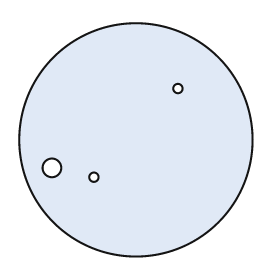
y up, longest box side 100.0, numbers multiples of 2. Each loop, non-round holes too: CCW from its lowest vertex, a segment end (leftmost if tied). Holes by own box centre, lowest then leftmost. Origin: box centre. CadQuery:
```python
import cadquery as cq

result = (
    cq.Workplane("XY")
    .moveTo(0.0, 0.0)
    .circle(50.0)
    .moveTo(-18.0, -16.0)
    .circle(2.0)
    .moveTo(-36.0, -12.0)
    .circle(4.0)
    .moveTo(18.0, 22.0)
    .circle(2.0)
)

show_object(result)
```